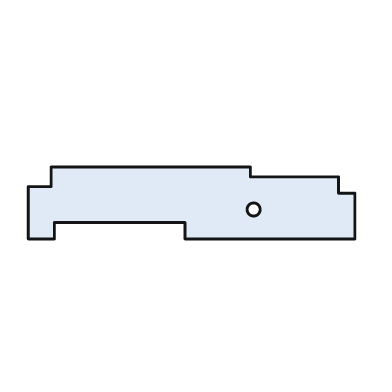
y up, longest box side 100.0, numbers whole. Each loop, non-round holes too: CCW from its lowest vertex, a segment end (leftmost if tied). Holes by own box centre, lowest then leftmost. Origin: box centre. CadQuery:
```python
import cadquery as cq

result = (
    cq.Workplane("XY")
    .moveTo(-50.0, -11.0)
    .lineTo(-42.0, -11.0)
    .lineTo(-42.0, -6.0)
    .lineTo(-2.0, -6.0)
    .lineTo(-2.0, -11.0)
    .lineTo(50.0, -11.0)
    .lineTo(50.0, 3.0)
    .lineTo(45.0, 3.0)
    .lineTo(45.0, 8.0)
    .lineTo(18.0, 8.0)
    .lineTo(18.0, 11.0)
    .lineTo(-43.0, 11.0)
    .lineTo(-43.0, 5.0)
    .lineTo(-50.0, 5.0)
    .close()
    .moveTo(19.0, -2.0)
    .circle(2.0)
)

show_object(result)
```